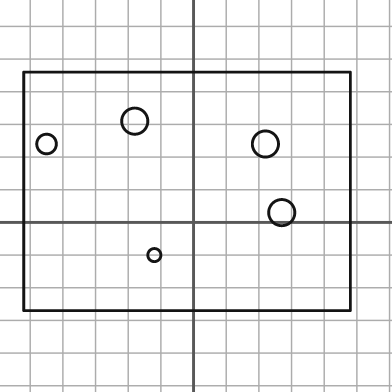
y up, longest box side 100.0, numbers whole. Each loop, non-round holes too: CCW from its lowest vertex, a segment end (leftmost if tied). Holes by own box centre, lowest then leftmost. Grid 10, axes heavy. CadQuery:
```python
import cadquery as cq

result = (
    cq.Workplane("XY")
    .moveTo(-52.0, -27.0)
    .lineTo(48.0, -27.0)
    .lineTo(48.0, 46.0)
    .lineTo(-52.0, 46.0)
    .close()
    .moveTo(-12.0, -10.0)
    .circle(2.0)
    .moveTo(27.0, 3.0)
    .circle(4.0)
    .moveTo(-45.0, 24.0)
    .circle(3.0)
    .moveTo(22.0, 24.0)
    .circle(4.0)
    .moveTo(-18.0, 31.0)
    .circle(4.0)
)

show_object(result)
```